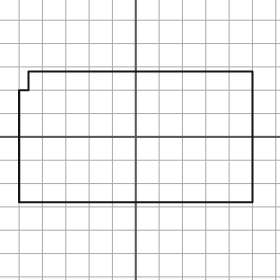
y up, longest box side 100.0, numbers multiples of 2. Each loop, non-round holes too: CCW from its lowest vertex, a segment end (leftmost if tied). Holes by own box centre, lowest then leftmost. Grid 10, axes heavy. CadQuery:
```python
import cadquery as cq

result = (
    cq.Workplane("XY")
    .moveTo(-50.0, -28.0)
    .lineTo(50.0, -28.0)
    .lineTo(50.0, 28.0)
    .lineTo(-46.0, 28.0)
    .lineTo(-46.0, 20.0)
    .lineTo(-50.0, 20.0)
    .close()
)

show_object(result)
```